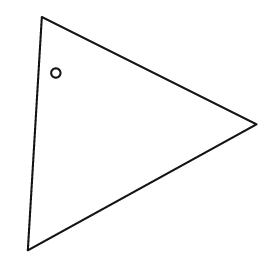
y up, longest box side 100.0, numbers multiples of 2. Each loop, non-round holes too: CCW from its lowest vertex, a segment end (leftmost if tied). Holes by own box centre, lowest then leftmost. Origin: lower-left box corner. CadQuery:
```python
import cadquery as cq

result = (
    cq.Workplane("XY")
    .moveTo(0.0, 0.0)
    .lineTo(98.0, 54.0)
    .lineTo(6.0, 100.0)
    .close()
    .moveTo(12.0, 76.0)
    .circle(2.0)
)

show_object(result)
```